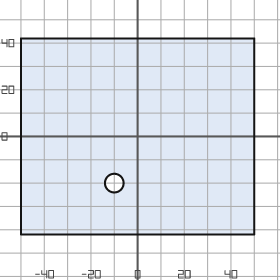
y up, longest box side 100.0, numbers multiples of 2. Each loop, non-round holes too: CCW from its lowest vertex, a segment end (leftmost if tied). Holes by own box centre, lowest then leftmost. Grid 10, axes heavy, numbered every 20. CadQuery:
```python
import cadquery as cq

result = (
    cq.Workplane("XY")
    .moveTo(-50.0, -42.0)
    .lineTo(50.0, -42.0)
    .lineTo(50.0, 42.0)
    .lineTo(-50.0, 42.0)
    .close()
    .moveTo(-10.0, -20.0)
    .circle(4.0)
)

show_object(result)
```